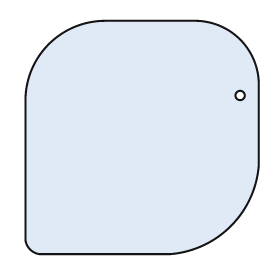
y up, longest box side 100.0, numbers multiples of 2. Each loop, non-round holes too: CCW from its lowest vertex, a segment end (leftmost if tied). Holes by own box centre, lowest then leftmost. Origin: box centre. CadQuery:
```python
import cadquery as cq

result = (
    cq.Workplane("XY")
    .moveTo(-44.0, -50.0)
    .lineTo(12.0, -50.0)
    .threePointArc((38.0, -38.0), (50.0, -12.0))
    .lineTo(50.0, 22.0)
    .threePointArc((42.0, 42.0), (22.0, 50.0))
    .lineTo(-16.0, 50.0)
    .threePointArc((-40.0, 40.0), (-50.0, 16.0))
    .lineTo(-50.0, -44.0)
    .threePointArc((-48.0, -48.0), (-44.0, -50.0))
    .close()
    .moveTo(42.0, 18.0)
    .circle(2.0)
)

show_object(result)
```